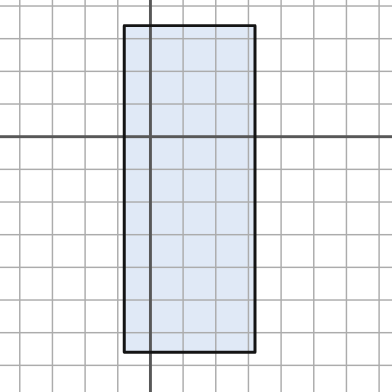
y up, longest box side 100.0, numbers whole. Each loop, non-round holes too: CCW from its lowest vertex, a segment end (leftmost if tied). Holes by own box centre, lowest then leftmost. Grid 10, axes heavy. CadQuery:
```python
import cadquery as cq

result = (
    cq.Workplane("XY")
    .moveTo(-8.0, -66.0)
    .lineTo(32.0, -66.0)
    .lineTo(32.0, 34.0)
    .lineTo(-8.0, 34.0)
    .close()
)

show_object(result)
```